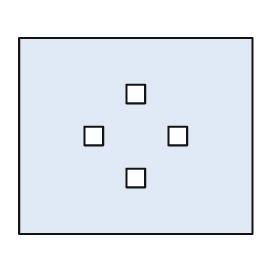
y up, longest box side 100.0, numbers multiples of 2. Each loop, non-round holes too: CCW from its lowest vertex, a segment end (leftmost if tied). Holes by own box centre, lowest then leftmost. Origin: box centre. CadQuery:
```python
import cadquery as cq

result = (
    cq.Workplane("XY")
    .moveTo(-50.0, -42.0)
    .lineTo(50.0, -42.0)
    .lineTo(50.0, 42.0)
    .lineTo(-50.0, 42.0)
    .close()
    .moveTo(-4.0, -22.0)
    .lineTo(4.0, -22.0)
    .lineTo(4.0, -14.0)
    .lineTo(-4.0, -14.0)
    .close()
    .moveTo(-22.0, -4.0)
    .lineTo(-14.0, -4.0)
    .lineTo(-14.0, 4.0)
    .lineTo(-22.0, 4.0)
    .close()
    .moveTo(14.0, -4.0)
    .lineTo(22.0, -4.0)
    .lineTo(22.0, 4.0)
    .lineTo(14.0, 4.0)
    .close()
    .moveTo(-4.0, 14.0)
    .lineTo(4.0, 14.0)
    .lineTo(4.0, 22.0)
    .lineTo(-4.0, 22.0)
    .close()
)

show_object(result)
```